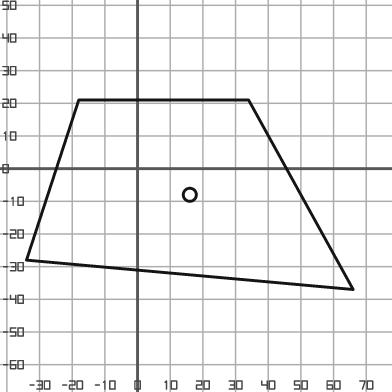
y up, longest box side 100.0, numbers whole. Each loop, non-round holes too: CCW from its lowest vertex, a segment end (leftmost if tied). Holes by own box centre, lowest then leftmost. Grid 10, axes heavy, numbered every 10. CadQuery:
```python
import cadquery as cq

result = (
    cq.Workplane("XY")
    .moveTo(66.0, -37.0)
    .lineTo(34.0, 21.0)
    .lineTo(-18.0, 21.0)
    .lineTo(-34.0, -28.0)
    .close()
    .moveTo(16.0, -8.0)
    .circle(2.0)
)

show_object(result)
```